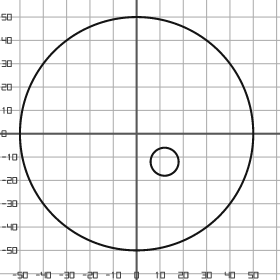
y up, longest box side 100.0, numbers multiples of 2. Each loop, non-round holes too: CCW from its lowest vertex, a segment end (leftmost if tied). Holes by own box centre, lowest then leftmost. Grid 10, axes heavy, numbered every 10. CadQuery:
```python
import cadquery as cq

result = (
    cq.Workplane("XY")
    .moveTo(0.0, 0.0)
    .circle(50.0)
    .moveTo(12.0, -12.0)
    .circle(6.0)
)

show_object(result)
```